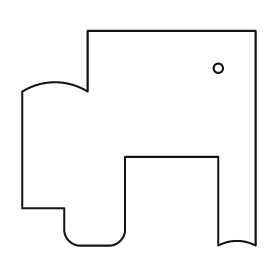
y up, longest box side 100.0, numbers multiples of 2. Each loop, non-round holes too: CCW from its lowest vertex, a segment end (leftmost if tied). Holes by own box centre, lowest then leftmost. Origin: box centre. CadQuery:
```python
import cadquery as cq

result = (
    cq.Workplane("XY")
    .moveTo(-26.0, -46.0)
    .lineTo(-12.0, -46.0)
    .threePointArc((-8.0, -44.0), (-6.0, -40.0))
    .lineTo(-6.0, -8.0)
    .lineTo(34.0, -8.0)
    .lineTo(34.0, -46.0)
    .threePointArc((42.0, -44.0), (50.0, -46.0))
    .lineTo(50.0, 46.0)
    .lineTo(-22.0, 46.0)
    .lineTo(-22.0, 20.0)
    .threePointArc((-36.0, 24.0), (-50.0, 20.0))
    .lineTo(-50.0, -30.0)
    .lineTo(-32.0, -30.0)
    .lineTo(-32.0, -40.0)
    .threePointArc((-30.0, -44.0), (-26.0, -46.0))
    .close()
    .moveTo(34.0, 30.0)
    .circle(2.0)
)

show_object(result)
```